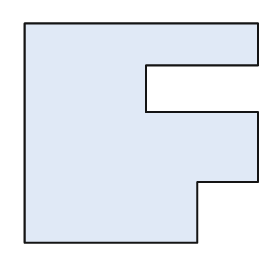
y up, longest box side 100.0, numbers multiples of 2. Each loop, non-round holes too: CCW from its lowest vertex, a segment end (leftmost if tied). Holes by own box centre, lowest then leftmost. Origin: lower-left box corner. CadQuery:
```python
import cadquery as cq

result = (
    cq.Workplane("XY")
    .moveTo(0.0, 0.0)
    .lineTo(74.0, 0.0)
    .lineTo(74.0, 26.0)
    .lineTo(100.0, 26.0)
    .lineTo(100.0, 56.0)
    .lineTo(52.0, 56.0)
    .lineTo(52.0, 76.0)
    .lineTo(100.0, 76.0)
    .lineTo(100.0, 94.0)
    .lineTo(0.0, 94.0)
    .close()
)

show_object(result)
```